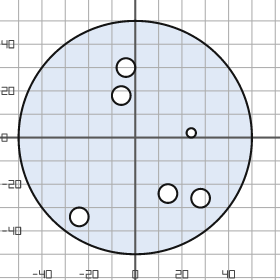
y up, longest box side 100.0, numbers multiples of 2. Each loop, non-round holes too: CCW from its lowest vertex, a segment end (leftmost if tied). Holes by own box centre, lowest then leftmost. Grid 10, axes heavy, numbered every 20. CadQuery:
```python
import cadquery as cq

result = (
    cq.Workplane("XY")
    .moveTo(0.0, 0.0)
    .circle(50.0)
    .moveTo(-24.0, -34.0)
    .circle(4.0)
    .moveTo(28.0, -26.0)
    .circle(4.0)
    .moveTo(14.0, -24.0)
    .circle(4.0)
    .moveTo(24.0, 2.0)
    .circle(2.0)
    .moveTo(-6.0, 18.0)
    .circle(4.0)
    .moveTo(-4.0, 30.0)
    .circle(4.0)
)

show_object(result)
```